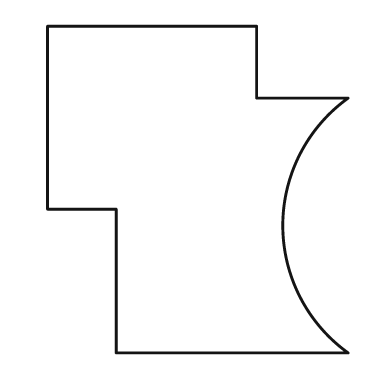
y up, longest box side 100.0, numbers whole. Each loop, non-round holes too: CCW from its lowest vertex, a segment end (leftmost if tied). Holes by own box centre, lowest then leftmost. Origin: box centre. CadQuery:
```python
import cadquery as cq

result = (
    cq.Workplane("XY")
    .moveTo(-25.0, -50.0)
    .lineTo(46.0, -50.0)
    .threePointArc((26.0, -11.0), (46.0, 28.0))
    .lineTo(18.0, 28.0)
    .lineTo(18.0, 50.0)
    .lineTo(-46.0, 50.0)
    .lineTo(-46.0, -6.0)
    .lineTo(-25.0, -6.0)
    .close()
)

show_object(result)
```